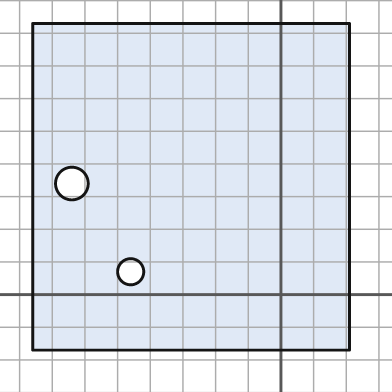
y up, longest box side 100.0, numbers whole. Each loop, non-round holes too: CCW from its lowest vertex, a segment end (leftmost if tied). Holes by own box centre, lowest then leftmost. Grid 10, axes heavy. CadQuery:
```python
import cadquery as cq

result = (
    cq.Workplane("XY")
    .moveTo(-76.0, -17.0)
    .lineTo(21.0, -17.0)
    .lineTo(21.0, 83.0)
    .lineTo(-76.0, 83.0)
    .close()
    .moveTo(-46.0, 7.0)
    .circle(4.0)
    .moveTo(-64.0, 34.0)
    .circle(5.0)
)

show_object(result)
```